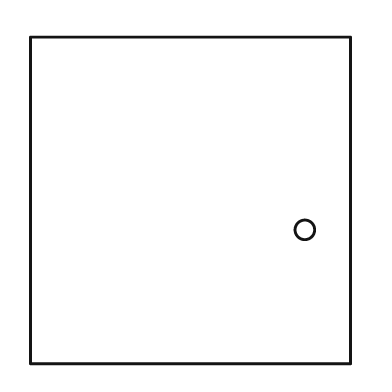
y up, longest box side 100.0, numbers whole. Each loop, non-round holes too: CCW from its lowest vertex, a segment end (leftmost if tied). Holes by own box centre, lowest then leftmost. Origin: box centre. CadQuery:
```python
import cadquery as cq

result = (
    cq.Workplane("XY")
    .moveTo(-49.0, -50.0)
    .lineTo(49.0, -50.0)
    .lineTo(49.0, 50.0)
    .lineTo(-49.0, 50.0)
    .close()
    .moveTo(35.0, -9.0)
    .circle(3.0)
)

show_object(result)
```